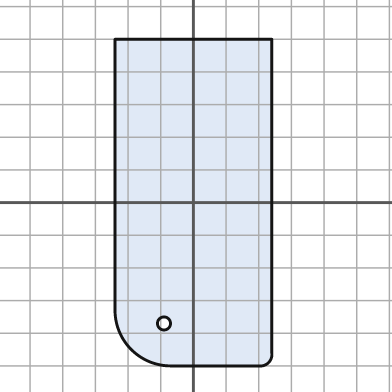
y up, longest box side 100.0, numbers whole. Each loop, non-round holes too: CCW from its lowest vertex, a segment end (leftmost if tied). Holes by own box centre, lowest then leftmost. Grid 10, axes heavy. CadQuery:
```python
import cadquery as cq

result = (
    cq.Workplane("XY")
    .moveTo(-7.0, -50.0)
    .lineTo(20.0, -50.0)
    .threePointArc((23.0, -49.0), (24.0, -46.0))
    .lineTo(24.0, 50.0)
    .lineTo(-24.0, 50.0)
    .lineTo(-24.0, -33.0)
    .threePointArc((-19.0, -45.0), (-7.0, -50.0))
    .close()
    .moveTo(-9.0, -37.0)
    .circle(2.0)
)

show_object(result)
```